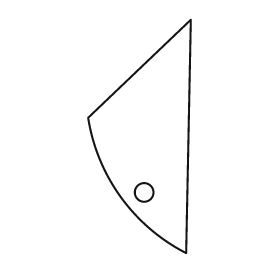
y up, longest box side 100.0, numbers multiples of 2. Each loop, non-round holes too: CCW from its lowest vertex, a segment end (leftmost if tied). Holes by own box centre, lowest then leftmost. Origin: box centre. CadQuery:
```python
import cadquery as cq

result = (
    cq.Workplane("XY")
    .moveTo(20.0, -50.0)
    .lineTo(22.0, 50.0)
    .lineTo(-22.0, 8.0)
    .threePointArc((-8.0, -26.0), (20.0, -50.0))
    .close()
    .moveTo(2.0, -24.0)
    .circle(4.0)
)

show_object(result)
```